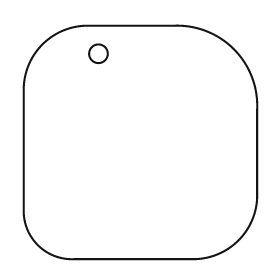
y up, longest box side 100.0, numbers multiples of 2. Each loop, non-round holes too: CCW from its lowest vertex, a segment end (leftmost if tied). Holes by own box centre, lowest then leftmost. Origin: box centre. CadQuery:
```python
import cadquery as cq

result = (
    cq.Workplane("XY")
    .moveTo(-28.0, -50.0)
    .lineTo(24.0, -50.0)
    .threePointArc((42.0, -42.0), (50.0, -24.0))
    .lineTo(50.0, 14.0)
    .threePointArc((40.0, 40.0), (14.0, 50.0))
    .lineTo(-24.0, 50.0)
    .threePointArc((-42.0, 42.0), (-50.0, 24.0))
    .lineTo(-50.0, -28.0)
    .threePointArc((-44.0, -44.0), (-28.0, -50.0))
    .close()
    .moveTo(-18.0, 38.0)
    .circle(4.0)
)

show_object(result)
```